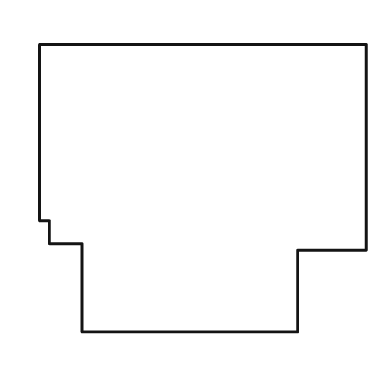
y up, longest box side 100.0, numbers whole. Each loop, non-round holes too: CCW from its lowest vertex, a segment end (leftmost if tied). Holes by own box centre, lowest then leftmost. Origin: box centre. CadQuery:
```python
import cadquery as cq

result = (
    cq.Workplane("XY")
    .moveTo(-37.0, -44.0)
    .lineTo(29.0, -44.0)
    .lineTo(29.0, -19.0)
    .lineTo(50.0, -19.0)
    .lineTo(50.0, 44.0)
    .lineTo(-50.0, 44.0)
    .lineTo(-50.0, -10.0)
    .lineTo(-47.0, -10.0)
    .lineTo(-47.0, -17.0)
    .lineTo(-37.0, -17.0)
    .close()
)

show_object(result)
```